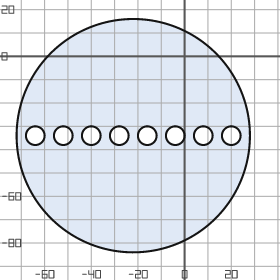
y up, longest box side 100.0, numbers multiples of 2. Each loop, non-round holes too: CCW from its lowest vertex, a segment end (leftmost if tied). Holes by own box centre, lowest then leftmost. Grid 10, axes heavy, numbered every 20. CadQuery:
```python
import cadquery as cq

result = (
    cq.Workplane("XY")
    .moveTo(-22.0, -34.0)
    .circle(50.0)
    .moveTo(-64.0, -34.0)
    .circle(4.0)
    .moveTo(-52.0, -34.0)
    .circle(4.0)
    .moveTo(-40.0, -34.0)
    .circle(4.0)
    .moveTo(-28.0, -34.0)
    .circle(4.0)
    .moveTo(-16.0, -34.0)
    .circle(4.0)
    .moveTo(-4.0, -34.0)
    .circle(4.0)
    .moveTo(8.0, -34.0)
    .circle(4.0)
    .moveTo(20.0, -34.0)
    .circle(4.0)
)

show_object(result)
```